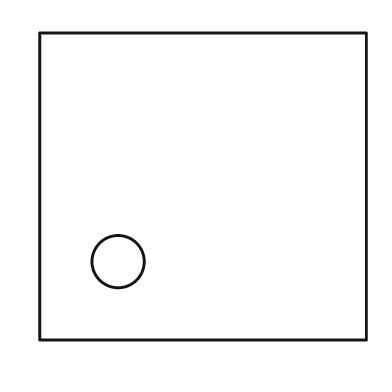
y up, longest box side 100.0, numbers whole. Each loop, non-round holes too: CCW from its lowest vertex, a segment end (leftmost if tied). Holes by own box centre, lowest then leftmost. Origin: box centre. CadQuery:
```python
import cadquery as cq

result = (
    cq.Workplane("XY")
    .moveTo(-50.0, -47.0)
    .lineTo(50.0, -47.0)
    .lineTo(50.0, 47.0)
    .lineTo(-50.0, 47.0)
    .close()
    .moveTo(-26.0, -23.0)
    .circle(8.0)
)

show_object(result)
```